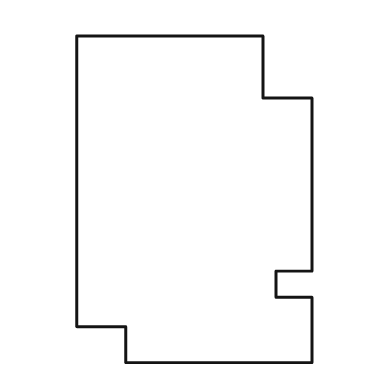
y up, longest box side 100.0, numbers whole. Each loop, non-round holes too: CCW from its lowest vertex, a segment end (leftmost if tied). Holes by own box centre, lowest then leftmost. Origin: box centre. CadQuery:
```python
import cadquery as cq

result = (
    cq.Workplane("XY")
    .moveTo(-21.0, -50.0)
    .lineTo(36.0, -50.0)
    .lineTo(36.0, -30.0)
    .lineTo(25.0, -30.0)
    .lineTo(25.0, -22.0)
    .lineTo(36.0, -22.0)
    .lineTo(36.0, 31.0)
    .lineTo(21.0, 31.0)
    .lineTo(21.0, 50.0)
    .lineTo(-36.0, 50.0)
    .lineTo(-36.0, -39.0)
    .lineTo(-21.0, -39.0)
    .close()
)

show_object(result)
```